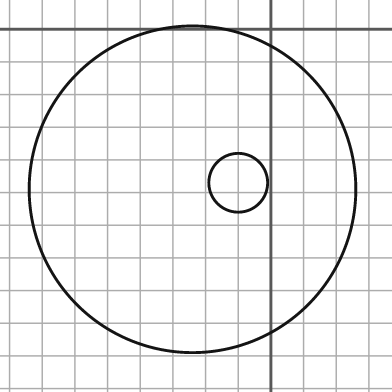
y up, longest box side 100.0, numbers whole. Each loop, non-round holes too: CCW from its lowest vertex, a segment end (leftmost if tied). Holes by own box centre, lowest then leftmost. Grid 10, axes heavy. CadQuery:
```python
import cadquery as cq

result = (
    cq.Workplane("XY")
    .moveTo(-24.0, -49.0)
    .circle(50.0)
    .moveTo(-10.0, -47.0)
    .circle(9.0)
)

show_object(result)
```